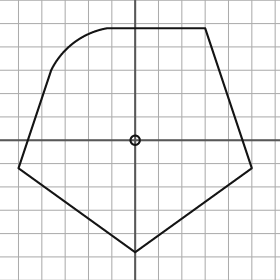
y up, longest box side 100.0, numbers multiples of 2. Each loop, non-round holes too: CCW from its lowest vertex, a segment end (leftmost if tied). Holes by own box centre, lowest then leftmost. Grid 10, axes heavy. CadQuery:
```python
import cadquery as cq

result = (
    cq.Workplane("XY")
    .moveTo(0.0, -48.0)
    .lineTo(50.0, -12.0)
    .lineTo(30.0, 48.0)
    .lineTo(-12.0, 48.0)
    .threePointArc((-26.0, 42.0), (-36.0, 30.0))
    .lineTo(-50.0, -12.0)
    .close()
    .moveTo(0.0, 0.0)
    .circle(2.0)
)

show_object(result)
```